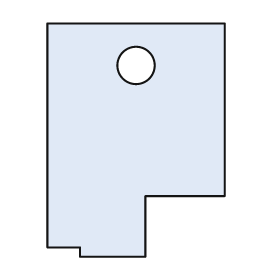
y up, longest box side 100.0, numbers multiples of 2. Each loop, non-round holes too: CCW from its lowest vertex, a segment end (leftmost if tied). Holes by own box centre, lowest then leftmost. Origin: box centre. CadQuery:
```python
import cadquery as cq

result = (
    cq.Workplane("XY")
    .moveTo(-24.0, -50.0)
    .lineTo(4.0, -50.0)
    .lineTo(4.0, -24.0)
    .lineTo(38.0, -24.0)
    .lineTo(38.0, 50.0)
    .lineTo(-38.0, 50.0)
    .lineTo(-38.0, -46.0)
    .lineTo(-24.0, -46.0)
    .close()
    .moveTo(0.0, 32.0)
    .circle(8.0)
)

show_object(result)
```